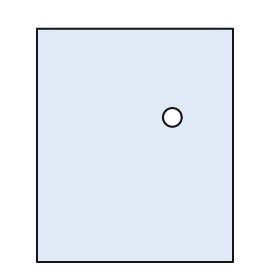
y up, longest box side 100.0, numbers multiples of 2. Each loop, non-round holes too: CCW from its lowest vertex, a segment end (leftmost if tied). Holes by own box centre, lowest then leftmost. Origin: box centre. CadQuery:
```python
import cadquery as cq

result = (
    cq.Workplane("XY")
    .moveTo(-42.0, -50.0)
    .lineTo(42.0, -50.0)
    .lineTo(42.0, 50.0)
    .lineTo(-42.0, 50.0)
    .close()
    .moveTo(16.0, 12.0)
    .circle(4.0)
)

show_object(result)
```